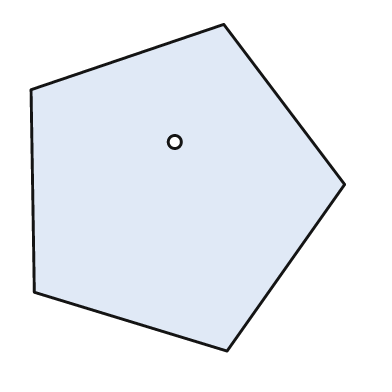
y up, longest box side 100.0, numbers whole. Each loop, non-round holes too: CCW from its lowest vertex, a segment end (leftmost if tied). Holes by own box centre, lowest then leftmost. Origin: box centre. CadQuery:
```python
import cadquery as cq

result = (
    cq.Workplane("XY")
    .moveTo(12.0, -50.0)
    .lineTo(48.0, 1.0)
    .lineTo(11.0, 50.0)
    .lineTo(-48.0, 30.0)
    .lineTo(-47.0, -32.0)
    .close()
    .moveTo(-4.0, 14.0)
    .circle(2.0)
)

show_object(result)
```